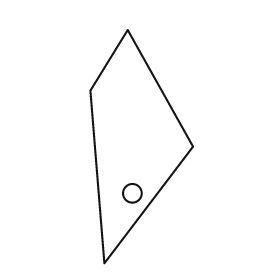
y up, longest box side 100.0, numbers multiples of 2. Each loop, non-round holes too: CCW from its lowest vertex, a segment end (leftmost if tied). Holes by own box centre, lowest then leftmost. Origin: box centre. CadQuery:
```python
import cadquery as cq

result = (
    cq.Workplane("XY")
    .moveTo(-16.0, -50.0)
    .lineTo(22.0, 0.0)
    .lineTo(-6.0, 50.0)
    .lineTo(-22.0, 24.0)
    .close()
    .moveTo(-4.0, -20.0)
    .circle(4.0)
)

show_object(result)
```